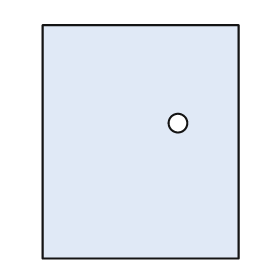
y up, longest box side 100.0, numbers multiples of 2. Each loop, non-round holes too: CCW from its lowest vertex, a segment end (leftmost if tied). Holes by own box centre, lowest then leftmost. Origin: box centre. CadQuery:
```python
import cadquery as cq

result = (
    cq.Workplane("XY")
    .moveTo(-42.0, -50.0)
    .lineTo(42.0, -50.0)
    .lineTo(42.0, 50.0)
    .lineTo(-42.0, 50.0)
    .close()
    .moveTo(16.0, 8.0)
    .circle(4.0)
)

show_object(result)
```